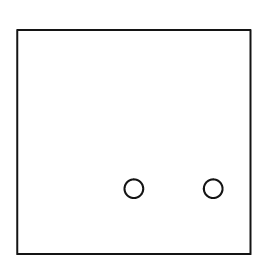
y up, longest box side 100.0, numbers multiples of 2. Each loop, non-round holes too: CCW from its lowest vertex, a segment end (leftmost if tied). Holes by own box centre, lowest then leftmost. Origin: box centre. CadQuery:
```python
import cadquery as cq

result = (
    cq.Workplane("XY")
    .moveTo(-50.0, -48.0)
    .lineTo(50.0, -48.0)
    .lineTo(50.0, 48.0)
    .lineTo(-50.0, 48.0)
    .close()
    .moveTo(0.0, -20.0)
    .circle(4.0)
    .moveTo(34.0, -20.0)
    .circle(4.0)
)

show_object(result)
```